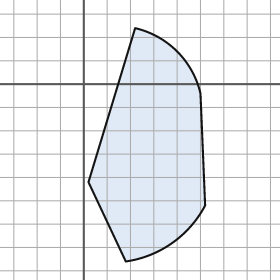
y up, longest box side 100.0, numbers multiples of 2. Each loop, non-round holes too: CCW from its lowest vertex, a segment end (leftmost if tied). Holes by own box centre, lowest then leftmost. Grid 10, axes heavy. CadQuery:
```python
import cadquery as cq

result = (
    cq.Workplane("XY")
    .moveTo(18.0, -76.0)
    .threePointArc((38.0, -68.0), (52.0, -52.0))
    .lineTo(50.0, -4.0)
    .threePointArc((40.0, 14.0), (22.0, 24.0))
    .lineTo(2.0, -42.0)
    .close()
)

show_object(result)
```